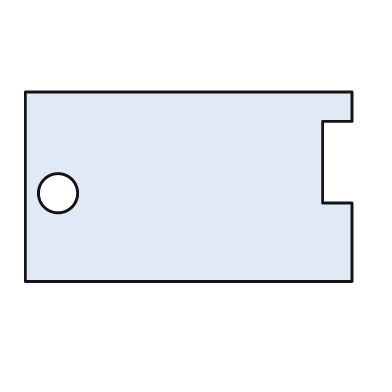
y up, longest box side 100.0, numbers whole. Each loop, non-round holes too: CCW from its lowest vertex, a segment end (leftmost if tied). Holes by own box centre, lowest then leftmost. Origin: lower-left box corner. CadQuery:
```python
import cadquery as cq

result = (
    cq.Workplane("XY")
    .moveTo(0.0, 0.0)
    .lineTo(100.0, 0.0)
    .lineTo(100.0, 24.0)
    .lineTo(91.0, 24.0)
    .lineTo(91.0, 49.0)
    .lineTo(100.0, 49.0)
    .lineTo(100.0, 58.0)
    .lineTo(0.0, 58.0)
    .close()
    .moveTo(10.0, 27.0)
    .circle(6.0)
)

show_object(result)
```